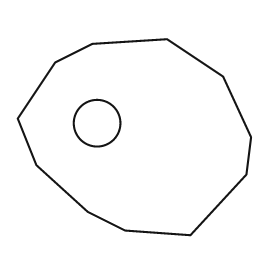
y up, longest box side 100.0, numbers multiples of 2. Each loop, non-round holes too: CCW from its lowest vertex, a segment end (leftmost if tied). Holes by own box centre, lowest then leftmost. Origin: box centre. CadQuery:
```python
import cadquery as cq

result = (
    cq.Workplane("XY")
    .moveTo(24.0, -42.0)
    .lineTo(48.0, -16.0)
    .lineTo(50.0, 0.0)
    .lineTo(38.0, 26.0)
    .lineTo(14.0, 42.0)
    .lineTo(-18.0, 40.0)
    .lineTo(-34.0, 32.0)
    .lineTo(-50.0, 8.0)
    .lineTo(-42.0, -12.0)
    .lineTo(-20.0, -32.0)
    .lineTo(-4.0, -40.0)
    .close()
    .moveTo(-16.0, 6.0)
    .circle(10.0)
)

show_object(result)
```